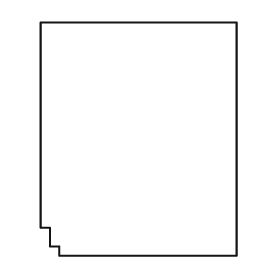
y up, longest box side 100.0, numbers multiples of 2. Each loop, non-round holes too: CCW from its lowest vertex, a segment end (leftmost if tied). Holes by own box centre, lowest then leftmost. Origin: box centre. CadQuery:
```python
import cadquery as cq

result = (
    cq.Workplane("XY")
    .moveTo(-34.0, -50.0)
    .lineTo(42.0, -50.0)
    .lineTo(42.0, 50.0)
    .lineTo(-42.0, 50.0)
    .lineTo(-42.0, -38.0)
    .lineTo(-38.0, -38.0)
    .lineTo(-38.0, -46.0)
    .lineTo(-34.0, -46.0)
    .close()
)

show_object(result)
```